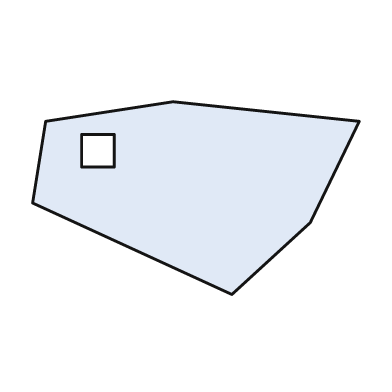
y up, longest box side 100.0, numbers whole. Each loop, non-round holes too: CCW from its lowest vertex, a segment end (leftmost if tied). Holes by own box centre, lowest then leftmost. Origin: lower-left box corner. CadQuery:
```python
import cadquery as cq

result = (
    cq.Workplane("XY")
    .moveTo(61.0, 0.0)
    .lineTo(85.0, 22.0)
    .lineTo(100.0, 53.0)
    .lineTo(43.0, 59.0)
    .lineTo(4.0, 53.0)
    .lineTo(0.0, 28.0)
    .close()
    .moveTo(15.0, 39.0)
    .lineTo(25.0, 39.0)
    .lineTo(25.0, 49.0)
    .lineTo(15.0, 49.0)
    .close()
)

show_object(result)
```